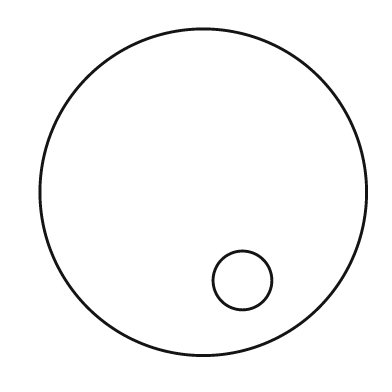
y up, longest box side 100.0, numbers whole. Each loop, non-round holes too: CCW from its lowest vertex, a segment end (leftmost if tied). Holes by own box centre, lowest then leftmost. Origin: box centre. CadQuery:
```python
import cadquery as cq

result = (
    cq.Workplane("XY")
    .moveTo(0.0, 0.0)
    .circle(50.0)
    .moveTo(12.0, -27.0)
    .circle(9.0)
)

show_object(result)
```